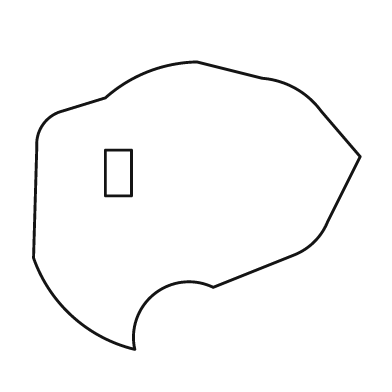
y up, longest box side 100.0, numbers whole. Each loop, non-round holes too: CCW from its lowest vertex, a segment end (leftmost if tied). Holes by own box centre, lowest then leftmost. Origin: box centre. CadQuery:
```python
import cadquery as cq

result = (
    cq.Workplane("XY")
    .moveTo(-19.0, -44.0)
    .threePointArc((-13.0, -27.0), (5.0, -25.0))
    .lineTo(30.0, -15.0)
    .threePointArc((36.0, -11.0), (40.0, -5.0))
    .lineTo(50.0, 15.0)
    .lineTo(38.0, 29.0)
    .threePointArc((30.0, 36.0), (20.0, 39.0))
    .lineTo(0.0, 44.0)
    .threePointArc((-15.0, 41.0), (-28.0, 33.0))
    .lineTo(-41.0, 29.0)
    .threePointArc((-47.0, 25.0), (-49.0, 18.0))
    .lineTo(-50.0, -16.0)
    .threePointArc((-38.0, -34.0), (-19.0, -44.0))
    .close()
    .moveTo(-28.0, 3.0)
    .lineTo(-20.0, 3.0)
    .lineTo(-20.0, 17.0)
    .lineTo(-28.0, 17.0)
    .close()
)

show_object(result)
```